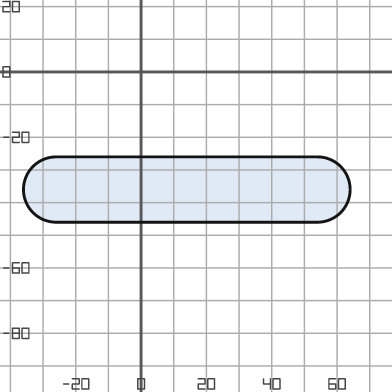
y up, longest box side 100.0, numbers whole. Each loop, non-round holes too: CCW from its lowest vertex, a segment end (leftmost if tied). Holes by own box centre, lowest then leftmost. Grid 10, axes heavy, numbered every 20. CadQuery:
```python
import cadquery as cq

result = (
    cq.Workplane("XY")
    .moveTo(-26.0, -46.0)
    .lineTo(54.0, -46.0)
    .threePointArc((64.0, -36.0), (54.0, -26.0))
    .lineTo(-26.0, -26.0)
    .threePointArc((-36.0, -36.0), (-26.0, -46.0))
    .close()
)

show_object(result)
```